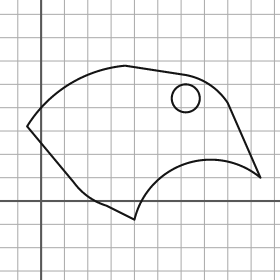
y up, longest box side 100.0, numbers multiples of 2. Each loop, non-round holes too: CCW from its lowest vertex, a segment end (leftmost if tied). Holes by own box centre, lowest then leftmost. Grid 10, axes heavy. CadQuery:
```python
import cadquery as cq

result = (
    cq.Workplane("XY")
    .moveTo(40.0, -8.0)
    .threePointArc((62.0, 16.0), (94.0, 10.0))
    .lineTo(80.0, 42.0)
    .threePointArc((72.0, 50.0), (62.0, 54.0))
    .lineTo(36.0, 58.0)
    .threePointArc((12.0, 50.0), (-6.0, 32.0))
    .lineTo(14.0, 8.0)
    .threePointArc((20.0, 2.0), (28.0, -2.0))
    .close()
    .moveTo(62.0, 44.0)
    .circle(6.0)
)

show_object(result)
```